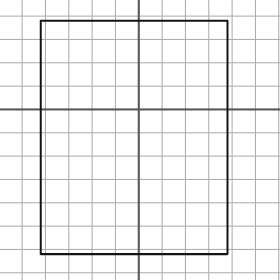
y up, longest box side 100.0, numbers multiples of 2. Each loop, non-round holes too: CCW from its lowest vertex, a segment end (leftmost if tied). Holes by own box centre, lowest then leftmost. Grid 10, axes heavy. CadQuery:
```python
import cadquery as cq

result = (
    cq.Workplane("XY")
    .moveTo(-42.0, -62.0)
    .lineTo(38.0, -62.0)
    .lineTo(38.0, 38.0)
    .lineTo(-42.0, 38.0)
    .close()
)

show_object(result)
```